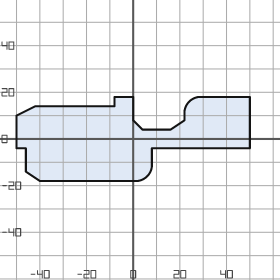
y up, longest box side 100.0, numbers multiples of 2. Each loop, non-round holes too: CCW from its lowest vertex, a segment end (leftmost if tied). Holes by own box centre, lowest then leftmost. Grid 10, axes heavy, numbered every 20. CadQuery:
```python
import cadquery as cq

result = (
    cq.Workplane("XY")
    .moveTo(-40.0, -18.0)
    .lineTo(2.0, -18.0)
    .threePointArc((6.0, -16.0), (8.0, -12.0))
    .lineTo(8.0, -4.0)
    .lineTo(50.0, -4.0)
    .lineTo(50.0, 18.0)
    .lineTo(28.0, 18.0)
    .threePointArc((24.0, 16.0), (22.0, 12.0))
    .lineTo(22.0, 8.0)
    .lineTo(16.0, 4.0)
    .lineTo(4.0, 4.0)
    .lineTo(0.0, 8.0)
    .lineTo(0.0, 18.0)
    .lineTo(-8.0, 18.0)
    .lineTo(-8.0, 14.0)
    .lineTo(-42.0, 14.0)
    .lineTo(-50.0, 10.0)
    .lineTo(-50.0, -4.0)
    .lineTo(-46.0, -4.0)
    .lineTo(-46.0, -14.0)
    .close()
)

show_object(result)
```